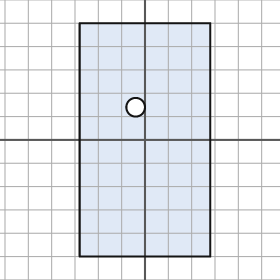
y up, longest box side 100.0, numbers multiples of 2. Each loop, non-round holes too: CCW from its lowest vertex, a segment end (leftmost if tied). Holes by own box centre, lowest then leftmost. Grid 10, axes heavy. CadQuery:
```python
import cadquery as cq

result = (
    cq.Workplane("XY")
    .moveTo(-28.0, -50.0)
    .lineTo(28.0, -50.0)
    .lineTo(28.0, 50.0)
    .lineTo(-28.0, 50.0)
    .close()
    .moveTo(-4.0, 14.0)
    .circle(4.0)
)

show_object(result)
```